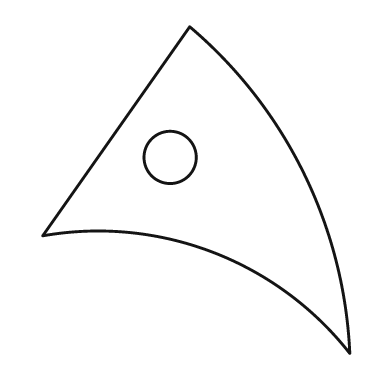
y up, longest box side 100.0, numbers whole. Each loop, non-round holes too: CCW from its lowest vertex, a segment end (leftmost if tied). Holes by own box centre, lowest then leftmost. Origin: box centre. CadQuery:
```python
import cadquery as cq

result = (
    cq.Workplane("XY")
    .moveTo(47.0, -50.0)
    .threePointArc((33.0, 5.0), (-2.0, 50.0))
    .lineTo(-47.0, -14.0)
    .threePointArc((5.0, -19.0), (47.0, -50.0))
    .close()
    .moveTo(-8.0, 10.0)
    .circle(8.0)
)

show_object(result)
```